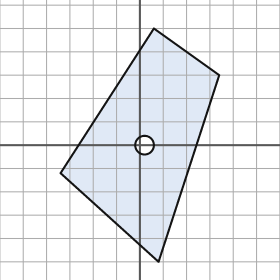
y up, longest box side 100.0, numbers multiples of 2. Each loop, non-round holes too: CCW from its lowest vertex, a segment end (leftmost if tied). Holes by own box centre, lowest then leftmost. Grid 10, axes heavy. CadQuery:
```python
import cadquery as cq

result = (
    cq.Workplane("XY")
    .moveTo(8.0, -50.0)
    .lineTo(34.0, 30.0)
    .lineTo(6.0, 50.0)
    .lineTo(-34.0, -12.0)
    .close()
    .moveTo(2.0, 0.0)
    .circle(4.0)
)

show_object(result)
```